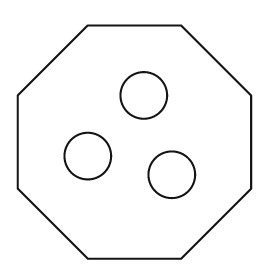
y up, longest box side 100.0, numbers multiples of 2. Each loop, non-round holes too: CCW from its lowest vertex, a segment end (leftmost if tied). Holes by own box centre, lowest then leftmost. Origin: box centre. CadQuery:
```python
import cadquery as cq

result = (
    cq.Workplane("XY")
    .moveTo(-20.0, -50.0)
    .lineTo(20.0, -50.0)
    .lineTo(50.0, -20.0)
    .lineTo(50.0, 20.0)
    .lineTo(20.0, 50.0)
    .lineTo(-20.0, 50.0)
    .lineTo(-50.0, 20.0)
    .lineTo(-50.0, -20.0)
    .close()
    .moveTo(16.0, -14.0)
    .circle(10.0)
    .moveTo(-20.0, -6.0)
    .circle(10.0)
    .moveTo(4.0, 20.0)
    .circle(10.0)
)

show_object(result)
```